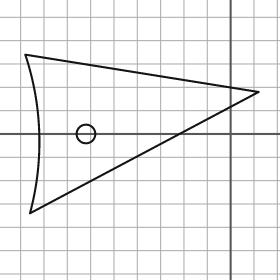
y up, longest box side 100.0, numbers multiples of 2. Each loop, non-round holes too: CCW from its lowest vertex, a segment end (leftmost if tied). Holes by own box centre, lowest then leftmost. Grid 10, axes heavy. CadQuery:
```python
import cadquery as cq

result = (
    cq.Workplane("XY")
    .moveTo(-86.0, -34.0)
    .lineTo(12.0, 18.0)
    .lineTo(-88.0, 34.0)
    .threePointArc((-82.0, 0.0), (-86.0, -34.0))
    .close()
    .moveTo(-62.0, 0.0)
    .circle(4.0)
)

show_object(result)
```